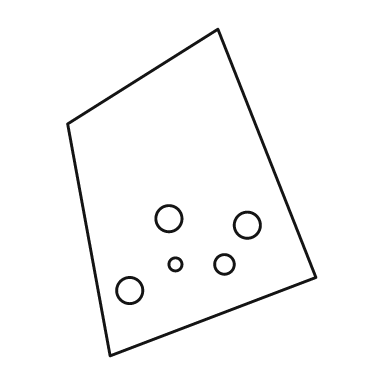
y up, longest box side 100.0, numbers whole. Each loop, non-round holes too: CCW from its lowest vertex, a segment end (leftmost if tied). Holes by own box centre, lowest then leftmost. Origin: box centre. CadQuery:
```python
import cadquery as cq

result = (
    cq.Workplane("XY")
    .moveTo(-25.0, -50.0)
    .lineTo(38.0, -26.0)
    .lineTo(8.0, 50.0)
    .lineTo(-38.0, 21.0)
    .close()
    .moveTo(-19.0, -30.0)
    .circle(4.0)
    .moveTo(-5.0, -22.0)
    .circle(2.0)
    .moveTo(10.0, -22.0)
    .circle(3.0)
    .moveTo(17.0, -10.0)
    .circle(4.0)
    .moveTo(-7.0, -8.0)
    .circle(4.0)
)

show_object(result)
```